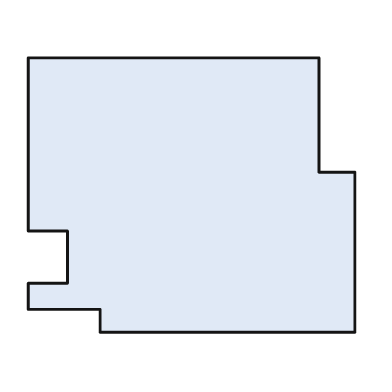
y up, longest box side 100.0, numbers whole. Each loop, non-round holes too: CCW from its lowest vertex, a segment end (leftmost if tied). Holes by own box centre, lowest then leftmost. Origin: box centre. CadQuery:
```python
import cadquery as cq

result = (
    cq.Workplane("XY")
    .moveTo(-28.0, -42.0)
    .lineTo(50.0, -42.0)
    .lineTo(50.0, 7.0)
    .lineTo(39.0, 7.0)
    .lineTo(39.0, 42.0)
    .lineTo(-50.0, 42.0)
    .lineTo(-50.0, -11.0)
    .lineTo(-38.0, -11.0)
    .lineTo(-38.0, -27.0)
    .lineTo(-50.0, -27.0)
    .lineTo(-50.0, -35.0)
    .lineTo(-28.0, -35.0)
    .close()
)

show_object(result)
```